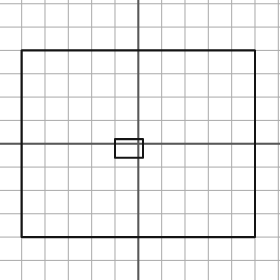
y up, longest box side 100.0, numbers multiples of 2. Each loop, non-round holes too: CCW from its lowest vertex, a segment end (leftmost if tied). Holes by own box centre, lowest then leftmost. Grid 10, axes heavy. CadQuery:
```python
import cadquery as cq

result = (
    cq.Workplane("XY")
    .moveTo(-50.0, -40.0)
    .lineTo(50.0, -40.0)
    .lineTo(50.0, 40.0)
    .lineTo(-50.0, 40.0)
    .close()
    .moveTo(-10.0, -6.0)
    .lineTo(2.0, -6.0)
    .lineTo(2.0, 2.0)
    .lineTo(-10.0, 2.0)
    .close()
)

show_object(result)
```